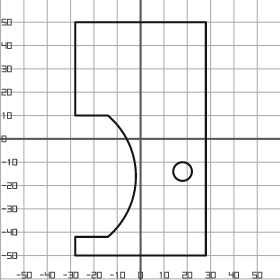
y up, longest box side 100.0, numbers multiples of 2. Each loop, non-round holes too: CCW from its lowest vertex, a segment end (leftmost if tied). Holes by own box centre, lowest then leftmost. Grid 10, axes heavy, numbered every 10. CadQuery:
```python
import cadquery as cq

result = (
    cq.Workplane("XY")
    .moveTo(-28.0, -50.0)
    .lineTo(28.0, -50.0)
    .lineTo(28.0, 50.0)
    .lineTo(-28.0, 50.0)
    .lineTo(-28.0, 10.0)
    .lineTo(-14.0, 10.0)
    .threePointArc((-2.0, -16.0), (-14.0, -42.0))
    .lineTo(-28.0, -42.0)
    .close()
    .moveTo(18.0, -14.0)
    .circle(4.0)
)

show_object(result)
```